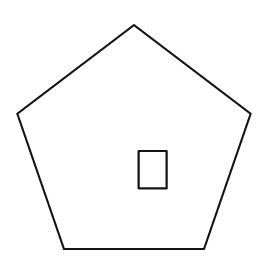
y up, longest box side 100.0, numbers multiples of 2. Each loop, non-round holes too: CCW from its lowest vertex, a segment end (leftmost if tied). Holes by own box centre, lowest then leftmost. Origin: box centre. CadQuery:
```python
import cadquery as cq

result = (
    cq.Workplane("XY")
    .moveTo(-30.0, -48.0)
    .lineTo(30.0, -48.0)
    .lineTo(50.0, 10.0)
    .lineTo(0.0, 48.0)
    .lineTo(-50.0, 10.0)
    .close()
    .moveTo(2.0, -22.0)
    .lineTo(14.0, -22.0)
    .lineTo(14.0, -6.0)
    .lineTo(2.0, -6.0)
    .close()
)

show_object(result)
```